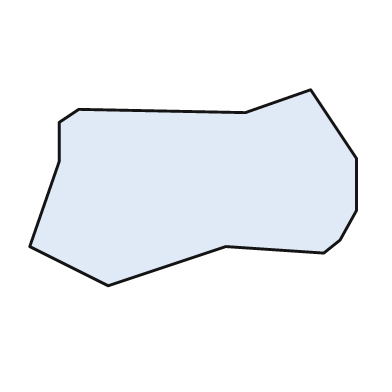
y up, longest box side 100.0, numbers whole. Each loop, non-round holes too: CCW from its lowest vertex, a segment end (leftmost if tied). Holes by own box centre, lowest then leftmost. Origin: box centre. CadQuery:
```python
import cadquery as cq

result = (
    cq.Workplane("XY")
    .moveTo(-26.0, -30.0)
    .lineTo(10.0, -18.0)
    .lineTo(40.0, -20.0)
    .lineTo(45.0, -16.0)
    .lineTo(50.0, -7.0)
    .lineTo(50.0, 9.0)
    .lineTo(36.0, 30.0)
    .lineTo(16.0, 23.0)
    .lineTo(-35.0, 24.0)
    .lineTo(-41.0, 20.0)
    .lineTo(-41.0, 8.0)
    .lineTo(-50.0, -18.0)
    .close()
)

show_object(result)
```